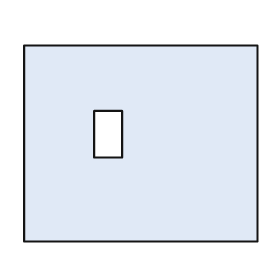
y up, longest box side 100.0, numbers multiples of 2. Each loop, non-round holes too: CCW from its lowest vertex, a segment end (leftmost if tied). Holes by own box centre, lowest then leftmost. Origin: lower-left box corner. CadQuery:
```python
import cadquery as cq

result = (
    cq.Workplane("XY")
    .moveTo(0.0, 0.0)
    .lineTo(100.0, 0.0)
    .lineTo(100.0, 84.0)
    .lineTo(0.0, 84.0)
    .close()
    .moveTo(30.0, 36.0)
    .lineTo(42.0, 36.0)
    .lineTo(42.0, 56.0)
    .lineTo(30.0, 56.0)
    .close()
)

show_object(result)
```